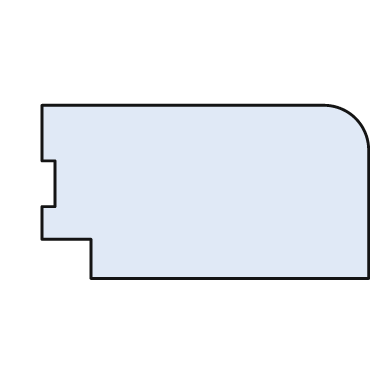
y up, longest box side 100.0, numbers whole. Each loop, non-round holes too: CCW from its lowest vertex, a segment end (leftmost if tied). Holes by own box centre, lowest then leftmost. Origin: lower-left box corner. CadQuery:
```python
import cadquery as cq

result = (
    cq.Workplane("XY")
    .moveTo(15.0, 0.0)
    .lineTo(100.0, 0.0)
    .lineTo(100.0, 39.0)
    .threePointArc((96.0, 49.0), (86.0, 53.0))
    .lineTo(0.0, 53.0)
    .lineTo(0.0, 36.0)
    .lineTo(4.0, 36.0)
    .lineTo(4.0, 22.0)
    .lineTo(0.0, 22.0)
    .lineTo(0.0, 12.0)
    .lineTo(15.0, 12.0)
    .close()
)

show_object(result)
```